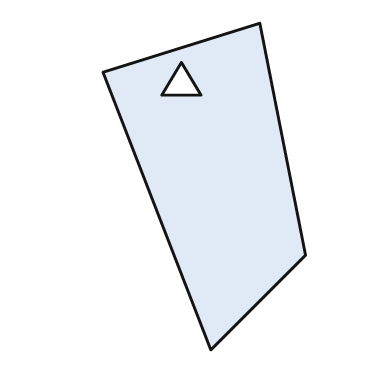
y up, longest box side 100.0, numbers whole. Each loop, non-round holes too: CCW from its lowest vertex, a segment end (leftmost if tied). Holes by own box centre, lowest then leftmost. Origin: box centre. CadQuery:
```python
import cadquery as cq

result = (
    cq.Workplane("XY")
    .moveTo(2.0, -50.0)
    .lineTo(31.0, -21.0)
    .lineTo(17.0, 50.0)
    .lineTo(-31.0, 35.0)
    .close()
    .moveTo(-13.0, 28.0)
    .lineTo(-1.0, 28.0)
    .lineTo(-7.0, 38.0)
    .close()
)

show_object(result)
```